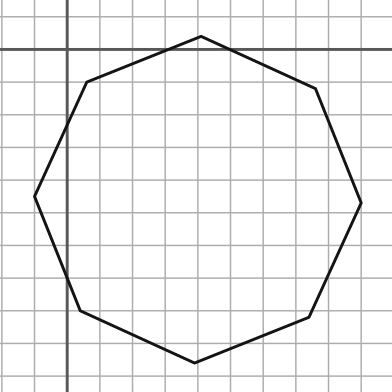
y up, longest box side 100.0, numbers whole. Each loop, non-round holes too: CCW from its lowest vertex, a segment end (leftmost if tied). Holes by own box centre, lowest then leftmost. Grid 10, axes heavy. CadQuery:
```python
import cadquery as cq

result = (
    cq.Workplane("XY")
    .moveTo(39.0, -96.0)
    .lineTo(74.0, -82.0)
    .lineTo(90.0, -47.0)
    .lineTo(76.0, -12.0)
    .lineTo(41.0, 4.0)
    .lineTo(6.0, -10.0)
    .lineTo(-10.0, -45.0)
    .lineTo(4.0, -80.0)
    .close()
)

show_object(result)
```